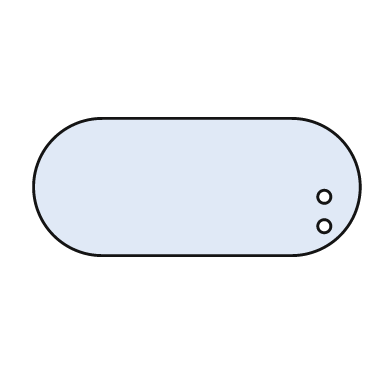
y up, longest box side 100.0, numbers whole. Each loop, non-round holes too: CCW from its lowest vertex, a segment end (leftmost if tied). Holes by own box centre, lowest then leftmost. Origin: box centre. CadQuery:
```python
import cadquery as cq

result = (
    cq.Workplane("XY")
    .moveTo(-29.0, -21.0)
    .lineTo(29.0, -21.0)
    .threePointArc((50.0, 0.0), (29.0, 21.0))
    .lineTo(-29.0, 21.0)
    .threePointArc((-50.0, 0.0), (-29.0, -21.0))
    .close()
    .moveTo(39.0, -12.0)
    .circle(2.0)
    .moveTo(39.0, -3.0)
    .circle(2.0)
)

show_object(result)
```